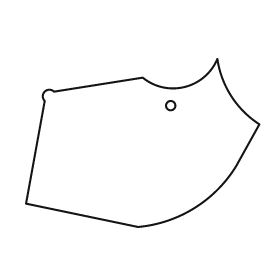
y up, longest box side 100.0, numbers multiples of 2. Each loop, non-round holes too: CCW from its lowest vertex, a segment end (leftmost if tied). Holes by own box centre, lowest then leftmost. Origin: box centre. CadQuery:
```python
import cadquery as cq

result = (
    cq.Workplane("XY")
    .moveTo(-2.0, -36.0)
    .threePointArc((22.0, -28.0), (40.0, -10.0))
    .lineTo(50.0, 8.0)
    .threePointArc((38.0, 20.0), (32.0, 36.0))
    .threePointArc((18.0, 24.0), (0.0, 28.0))
    .lineTo(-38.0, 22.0)
    .threePointArc((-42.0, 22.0), (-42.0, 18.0))
    .lineTo(-50.0, -26.0)
    .close()
    .moveTo(12.0, 16.0)
    .circle(2.0)
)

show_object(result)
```